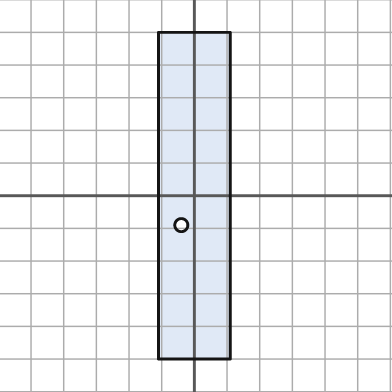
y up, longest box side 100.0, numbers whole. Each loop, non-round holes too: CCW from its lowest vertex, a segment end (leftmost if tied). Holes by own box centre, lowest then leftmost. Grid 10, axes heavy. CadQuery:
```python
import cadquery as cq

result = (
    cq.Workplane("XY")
    .moveTo(-11.0, -50.0)
    .lineTo(11.0, -50.0)
    .lineTo(11.0, 50.0)
    .lineTo(-11.0, 50.0)
    .close()
    .moveTo(-4.0, -9.0)
    .circle(2.0)
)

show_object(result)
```